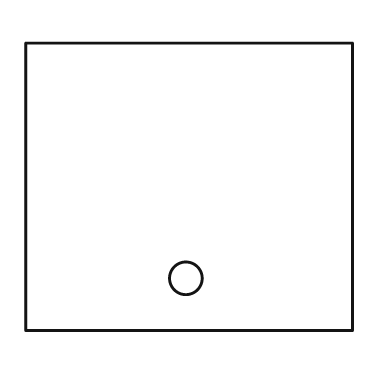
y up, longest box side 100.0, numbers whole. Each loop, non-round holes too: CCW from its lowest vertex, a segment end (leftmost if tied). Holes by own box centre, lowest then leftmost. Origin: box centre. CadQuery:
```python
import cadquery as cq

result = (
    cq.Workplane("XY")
    .moveTo(-50.0, -44.0)
    .lineTo(50.0, -44.0)
    .lineTo(50.0, 44.0)
    .lineTo(-50.0, 44.0)
    .close()
    .moveTo(-1.0, -28.0)
    .circle(5.0)
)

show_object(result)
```